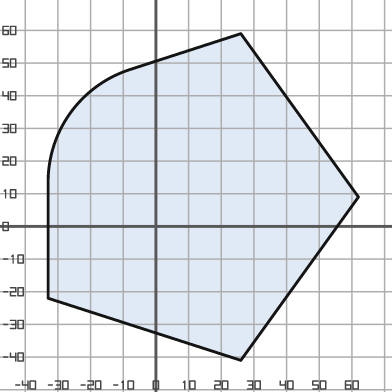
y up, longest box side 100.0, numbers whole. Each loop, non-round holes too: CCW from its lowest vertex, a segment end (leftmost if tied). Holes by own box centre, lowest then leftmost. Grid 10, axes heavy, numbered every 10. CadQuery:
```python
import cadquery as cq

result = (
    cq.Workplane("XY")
    .moveTo(26.0, -41.0)
    .lineTo(62.0, 9.0)
    .lineTo(26.0, 59.0)
    .lineTo(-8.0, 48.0)
    .threePointArc((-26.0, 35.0), (-33.0, 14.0))
    .lineTo(-33.0, -22.0)
    .close()
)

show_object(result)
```